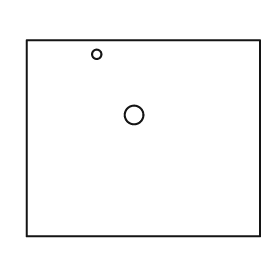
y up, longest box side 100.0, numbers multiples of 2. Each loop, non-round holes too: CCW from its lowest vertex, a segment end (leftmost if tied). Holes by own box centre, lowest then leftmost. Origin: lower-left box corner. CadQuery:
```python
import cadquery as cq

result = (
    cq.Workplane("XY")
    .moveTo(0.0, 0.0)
    .lineTo(100.0, 0.0)
    .lineTo(100.0, 84.0)
    .lineTo(0.0, 84.0)
    .close()
    .moveTo(46.0, 52.0)
    .circle(4.0)
    .moveTo(30.0, 78.0)
    .circle(2.0)
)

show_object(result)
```